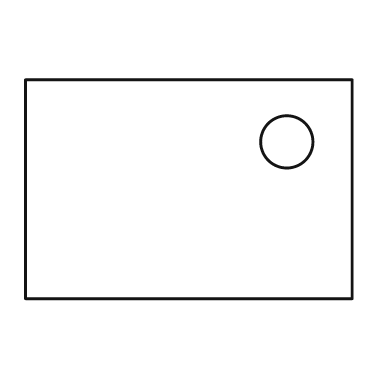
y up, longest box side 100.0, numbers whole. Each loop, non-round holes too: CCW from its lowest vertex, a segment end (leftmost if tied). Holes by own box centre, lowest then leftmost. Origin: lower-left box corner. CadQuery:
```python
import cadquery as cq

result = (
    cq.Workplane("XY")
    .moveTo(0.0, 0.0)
    .lineTo(100.0, 0.0)
    .lineTo(100.0, 67.0)
    .lineTo(0.0, 67.0)
    .close()
    .moveTo(80.0, 48.0)
    .circle(8.0)
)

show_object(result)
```